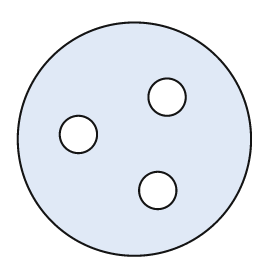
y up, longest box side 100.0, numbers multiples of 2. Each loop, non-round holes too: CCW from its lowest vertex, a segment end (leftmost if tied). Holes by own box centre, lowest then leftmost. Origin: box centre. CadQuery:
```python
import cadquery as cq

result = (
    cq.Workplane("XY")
    .moveTo(0.0, 0.0)
    .circle(50.0)
    .moveTo(10.0, -22.0)
    .circle(8.0)
    .moveTo(-24.0, 2.0)
    .circle(8.0)
    .moveTo(14.0, 18.0)
    .circle(8.0)
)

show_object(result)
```